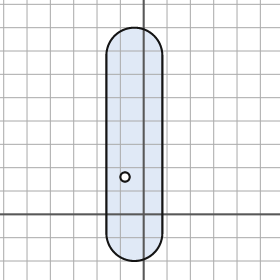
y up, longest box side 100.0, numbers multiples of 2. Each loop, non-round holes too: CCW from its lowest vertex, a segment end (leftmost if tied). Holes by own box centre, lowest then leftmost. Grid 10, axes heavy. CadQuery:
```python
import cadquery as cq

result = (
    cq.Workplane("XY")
    .moveTo(-16.0, -8.0)
    .threePointArc((-4.0, -20.0), (8.0, -8.0))
    .lineTo(8.0, 68.0)
    .threePointArc((-4.0, 80.0), (-16.0, 68.0))
    .close()
    .moveTo(-8.0, 16.0)
    .circle(2.0)
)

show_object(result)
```